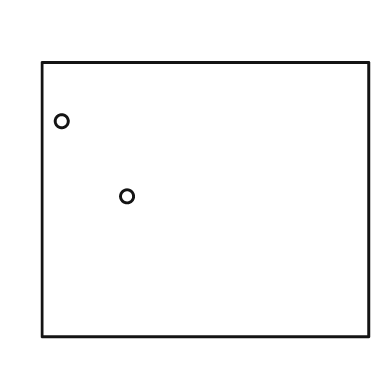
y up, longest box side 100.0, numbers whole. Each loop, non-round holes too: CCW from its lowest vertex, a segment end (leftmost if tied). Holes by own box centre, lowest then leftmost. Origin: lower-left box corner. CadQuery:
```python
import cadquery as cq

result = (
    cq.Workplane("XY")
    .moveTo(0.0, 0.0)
    .lineTo(100.0, 0.0)
    .lineTo(100.0, 84.0)
    .lineTo(0.0, 84.0)
    .close()
    .moveTo(26.0, 43.0)
    .circle(2.0)
    .moveTo(6.0, 66.0)
    .circle(2.0)
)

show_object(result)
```